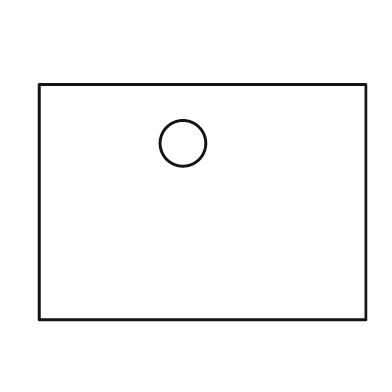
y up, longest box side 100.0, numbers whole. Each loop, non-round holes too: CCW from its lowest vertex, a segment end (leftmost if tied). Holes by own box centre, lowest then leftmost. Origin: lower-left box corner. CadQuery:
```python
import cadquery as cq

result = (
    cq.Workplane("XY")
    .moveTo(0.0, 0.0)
    .lineTo(100.0, 0.0)
    .lineTo(100.0, 72.0)
    .lineTo(0.0, 72.0)
    .close()
    .moveTo(44.0, 54.0)
    .circle(7.0)
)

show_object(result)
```